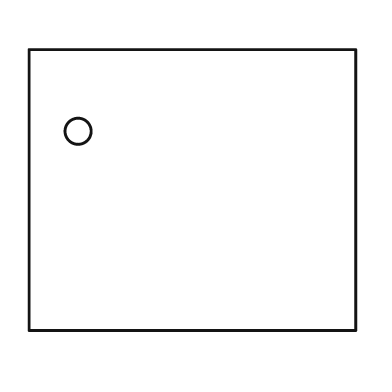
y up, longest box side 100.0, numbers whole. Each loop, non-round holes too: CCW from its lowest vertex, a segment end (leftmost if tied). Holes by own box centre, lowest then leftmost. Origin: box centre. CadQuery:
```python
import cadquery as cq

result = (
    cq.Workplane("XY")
    .moveTo(-50.0, -43.0)
    .lineTo(50.0, -43.0)
    .lineTo(50.0, 43.0)
    .lineTo(-50.0, 43.0)
    .close()
    .moveTo(-35.0, 18.0)
    .circle(4.0)
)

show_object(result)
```